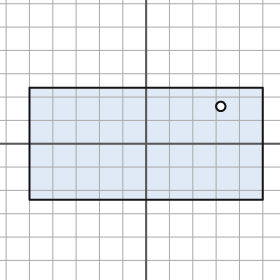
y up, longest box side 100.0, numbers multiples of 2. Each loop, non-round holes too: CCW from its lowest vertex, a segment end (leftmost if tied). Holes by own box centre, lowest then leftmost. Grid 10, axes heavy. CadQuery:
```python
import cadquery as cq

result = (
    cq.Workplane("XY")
    .moveTo(-50.0, -24.0)
    .lineTo(50.0, -24.0)
    .lineTo(50.0, 24.0)
    .lineTo(-50.0, 24.0)
    .close()
    .moveTo(32.0, 16.0)
    .circle(2.0)
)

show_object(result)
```